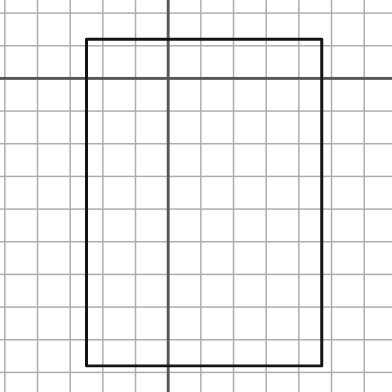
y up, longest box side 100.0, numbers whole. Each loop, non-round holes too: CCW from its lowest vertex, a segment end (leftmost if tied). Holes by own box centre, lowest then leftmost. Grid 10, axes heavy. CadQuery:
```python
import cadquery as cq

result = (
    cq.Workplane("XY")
    .moveTo(-25.0, -88.0)
    .lineTo(47.0, -88.0)
    .lineTo(47.0, 12.0)
    .lineTo(-25.0, 12.0)
    .close()
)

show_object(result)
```